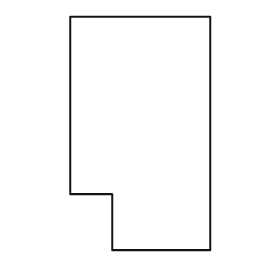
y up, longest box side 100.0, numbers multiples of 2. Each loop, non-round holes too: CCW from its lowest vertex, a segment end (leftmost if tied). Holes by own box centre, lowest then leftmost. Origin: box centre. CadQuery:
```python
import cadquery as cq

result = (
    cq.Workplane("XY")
    .moveTo(-12.0, -50.0)
    .lineTo(30.0, -50.0)
    .lineTo(30.0, 50.0)
    .lineTo(-30.0, 50.0)
    .lineTo(-30.0, -26.0)
    .lineTo(-12.0, -26.0)
    .close()
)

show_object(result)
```